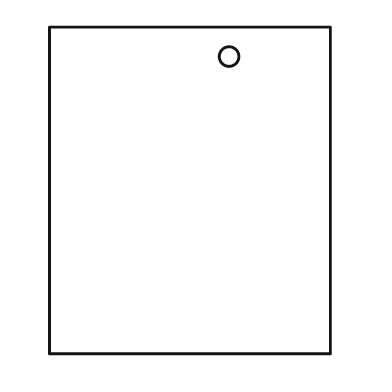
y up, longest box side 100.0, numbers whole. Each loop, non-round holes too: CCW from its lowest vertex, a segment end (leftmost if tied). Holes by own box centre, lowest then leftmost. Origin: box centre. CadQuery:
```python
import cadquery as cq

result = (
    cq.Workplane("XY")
    .moveTo(-43.0, -50.0)
    .lineTo(43.0, -50.0)
    .lineTo(43.0, 50.0)
    .lineTo(-43.0, 50.0)
    .close()
    .moveTo(12.0, 41.0)
    .circle(3.0)
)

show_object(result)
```